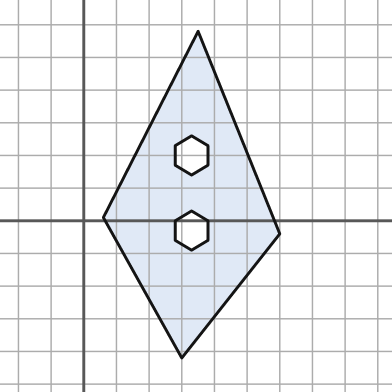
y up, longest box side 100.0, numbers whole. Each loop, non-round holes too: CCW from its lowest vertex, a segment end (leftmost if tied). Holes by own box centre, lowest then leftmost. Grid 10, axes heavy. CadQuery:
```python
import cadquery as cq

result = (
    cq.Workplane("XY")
    .moveTo(30.0, -42.0)
    .lineTo(60.0, -4.0)
    .lineTo(35.0, 58.0)
    .lineTo(6.0, 1.0)
    .close()
    .moveTo(33.0, -9.0)
    .lineTo(38.0, -6.0)
    .lineTo(38.0, 0.0)
    .lineTo(33.0, 3.0)
    .lineTo(28.0, 0.0)
    .lineTo(28.0, -6.0)
    .close()
    .moveTo(33.0, 14.0)
    .lineTo(38.0, 17.0)
    .lineTo(38.0, 23.0)
    .lineTo(33.0, 26.0)
    .lineTo(28.0, 23.0)
    .lineTo(28.0, 17.0)
    .close()
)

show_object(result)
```